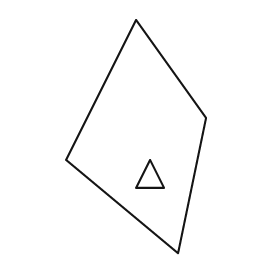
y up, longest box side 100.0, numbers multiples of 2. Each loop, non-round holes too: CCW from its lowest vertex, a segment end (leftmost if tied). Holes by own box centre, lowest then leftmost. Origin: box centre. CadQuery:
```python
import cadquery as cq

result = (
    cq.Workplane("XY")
    .moveTo(18.0, -50.0)
    .lineTo(30.0, 8.0)
    .lineTo(0.0, 50.0)
    .lineTo(-30.0, -10.0)
    .close()
    .moveTo(0.0, -22.0)
    .lineTo(12.0, -22.0)
    .lineTo(6.0, -10.0)
    .close()
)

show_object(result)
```